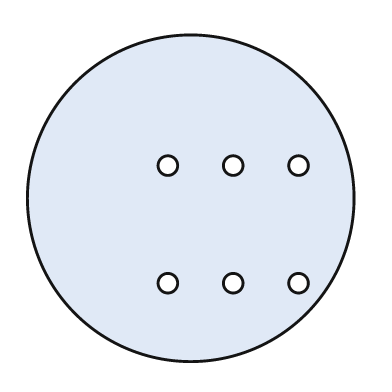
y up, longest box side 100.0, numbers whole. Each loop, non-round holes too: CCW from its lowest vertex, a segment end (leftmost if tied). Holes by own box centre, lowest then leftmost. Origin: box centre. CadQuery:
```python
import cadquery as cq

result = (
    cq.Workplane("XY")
    .moveTo(0.0, 0.0)
    .circle(50.0)
    .moveTo(-7.0, -26.0)
    .circle(3.0)
    .moveTo(13.0, -26.0)
    .circle(3.0)
    .moveTo(33.0, -26.0)
    .circle(3.0)
    .moveTo(-7.0, 10.0)
    .circle(3.0)
    .moveTo(13.0, 10.0)
    .circle(3.0)
    .moveTo(33.0, 10.0)
    .circle(3.0)
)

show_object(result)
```